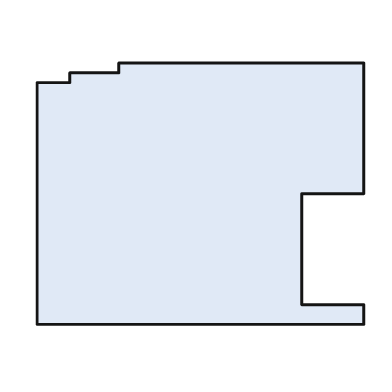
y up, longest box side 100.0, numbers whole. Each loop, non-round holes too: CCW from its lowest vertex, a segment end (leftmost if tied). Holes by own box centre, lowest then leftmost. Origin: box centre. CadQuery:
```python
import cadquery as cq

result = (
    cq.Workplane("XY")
    .moveTo(-50.0, -40.0)
    .lineTo(50.0, -40.0)
    .lineTo(50.0, -34.0)
    .lineTo(31.0, -34.0)
    .lineTo(31.0, 0.0)
    .lineTo(50.0, 0.0)
    .lineTo(50.0, 40.0)
    .lineTo(-25.0, 40.0)
    .lineTo(-25.0, 37.0)
    .lineTo(-40.0, 37.0)
    .lineTo(-40.0, 34.0)
    .lineTo(-50.0, 34.0)
    .close()
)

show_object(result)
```